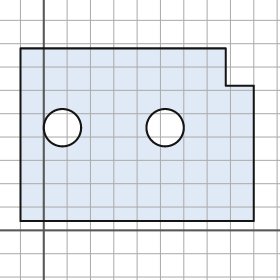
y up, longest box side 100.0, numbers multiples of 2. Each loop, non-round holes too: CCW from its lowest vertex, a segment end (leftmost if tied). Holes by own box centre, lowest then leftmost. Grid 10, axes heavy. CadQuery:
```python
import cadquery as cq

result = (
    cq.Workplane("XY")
    .moveTo(-10.0, 4.0)
    .lineTo(90.0, 4.0)
    .lineTo(90.0, 62.0)
    .lineTo(78.0, 62.0)
    .lineTo(78.0, 78.0)
    .lineTo(-10.0, 78.0)
    .close()
    .moveTo(8.0, 44.0)
    .circle(8.0)
    .moveTo(52.0, 44.0)
    .circle(8.0)
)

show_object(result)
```